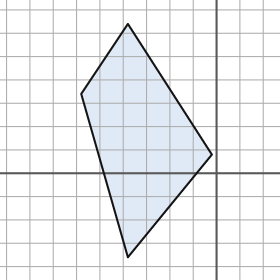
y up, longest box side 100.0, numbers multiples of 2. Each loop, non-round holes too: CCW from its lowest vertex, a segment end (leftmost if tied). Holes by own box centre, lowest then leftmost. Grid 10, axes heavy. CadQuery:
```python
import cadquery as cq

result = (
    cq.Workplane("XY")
    .moveTo(-38.0, -36.0)
    .lineTo(-2.0, 8.0)
    .lineTo(-38.0, 64.0)
    .lineTo(-58.0, 34.0)
    .close()
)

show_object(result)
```